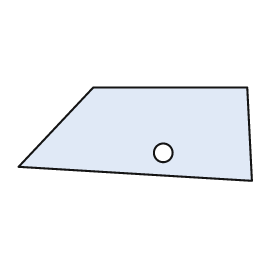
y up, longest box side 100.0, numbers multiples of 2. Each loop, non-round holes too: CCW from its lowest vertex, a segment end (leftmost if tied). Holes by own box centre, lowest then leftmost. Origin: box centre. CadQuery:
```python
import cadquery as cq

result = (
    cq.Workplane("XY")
    .moveTo(50.0, -20.0)
    .lineTo(48.0, 20.0)
    .lineTo(-18.0, 20.0)
    .lineTo(-50.0, -14.0)
    .close()
    .moveTo(12.0, -8.0)
    .circle(4.0)
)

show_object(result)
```